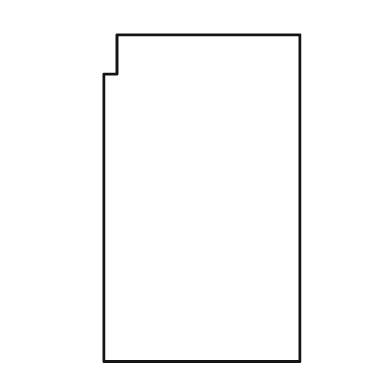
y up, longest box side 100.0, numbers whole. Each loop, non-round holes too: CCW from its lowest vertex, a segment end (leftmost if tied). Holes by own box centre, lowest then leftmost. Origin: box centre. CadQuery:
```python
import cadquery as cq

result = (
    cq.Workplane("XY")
    .moveTo(-30.0, -50.0)
    .lineTo(30.0, -50.0)
    .lineTo(30.0, 50.0)
    .lineTo(-26.0, 50.0)
    .lineTo(-26.0, 38.0)
    .lineTo(-30.0, 38.0)
    .close()
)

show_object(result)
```